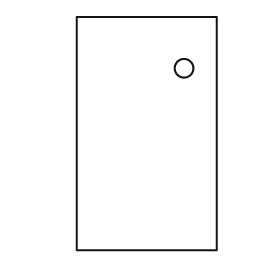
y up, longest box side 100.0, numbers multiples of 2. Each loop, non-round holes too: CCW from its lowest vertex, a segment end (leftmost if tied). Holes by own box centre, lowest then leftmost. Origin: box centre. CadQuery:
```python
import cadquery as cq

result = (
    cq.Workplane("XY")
    .moveTo(-30.0, -50.0)
    .lineTo(30.0, -50.0)
    .lineTo(30.0, 50.0)
    .lineTo(-30.0, 50.0)
    .close()
    .moveTo(16.0, 28.0)
    .circle(4.0)
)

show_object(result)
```